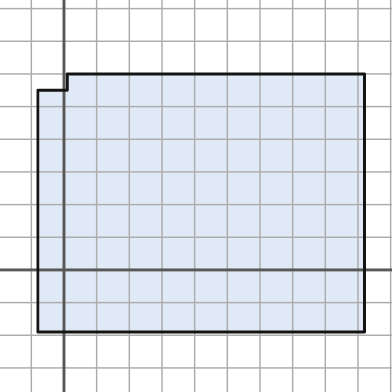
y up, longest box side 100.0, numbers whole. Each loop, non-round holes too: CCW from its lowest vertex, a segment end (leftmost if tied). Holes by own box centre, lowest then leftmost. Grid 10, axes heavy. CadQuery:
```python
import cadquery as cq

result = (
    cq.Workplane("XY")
    .moveTo(-8.0, -19.0)
    .lineTo(92.0, -19.0)
    .lineTo(92.0, 60.0)
    .lineTo(1.0, 60.0)
    .lineTo(1.0, 55.0)
    .lineTo(-8.0, 55.0)
    .close()
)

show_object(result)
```